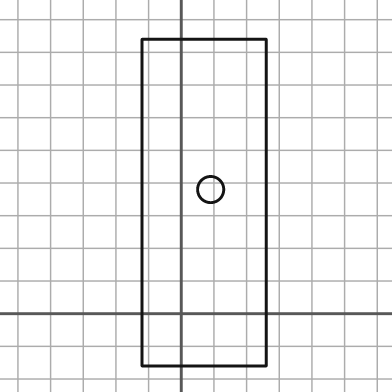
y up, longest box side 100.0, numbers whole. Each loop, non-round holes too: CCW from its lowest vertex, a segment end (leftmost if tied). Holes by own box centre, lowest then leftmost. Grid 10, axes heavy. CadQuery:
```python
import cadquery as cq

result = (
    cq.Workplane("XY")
    .moveTo(-12.0, -16.0)
    .lineTo(26.0, -16.0)
    .lineTo(26.0, 84.0)
    .lineTo(-12.0, 84.0)
    .close()
    .moveTo(9.0, 38.0)
    .circle(4.0)
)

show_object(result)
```